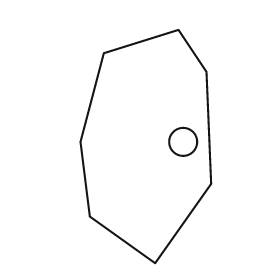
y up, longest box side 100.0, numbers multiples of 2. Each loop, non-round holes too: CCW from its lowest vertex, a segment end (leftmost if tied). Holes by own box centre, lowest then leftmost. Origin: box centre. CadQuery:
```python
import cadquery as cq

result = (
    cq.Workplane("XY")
    .moveTo(4.0, -50.0)
    .lineTo(28.0, -16.0)
    .lineTo(26.0, 32.0)
    .lineTo(14.0, 50.0)
    .lineTo(-18.0, 40.0)
    .lineTo(-28.0, 2.0)
    .lineTo(-24.0, -30.0)
    .close()
    .moveTo(16.0, 2.0)
    .circle(6.0)
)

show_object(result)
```